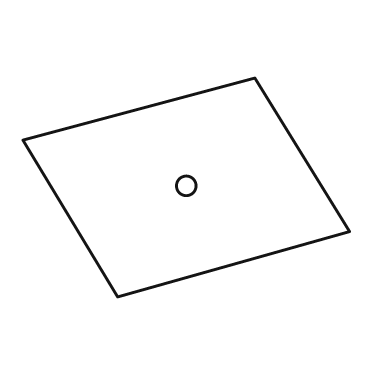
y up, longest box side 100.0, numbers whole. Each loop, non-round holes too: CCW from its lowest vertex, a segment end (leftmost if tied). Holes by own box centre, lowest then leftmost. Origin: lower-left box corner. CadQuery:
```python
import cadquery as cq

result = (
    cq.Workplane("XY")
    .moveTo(29.0, 0.0)
    .lineTo(100.0, 20.0)
    .lineTo(71.0, 67.0)
    .lineTo(0.0, 48.0)
    .close()
    .moveTo(50.0, 34.0)
    .circle(3.0)
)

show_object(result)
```